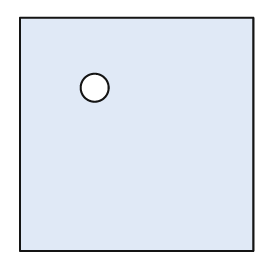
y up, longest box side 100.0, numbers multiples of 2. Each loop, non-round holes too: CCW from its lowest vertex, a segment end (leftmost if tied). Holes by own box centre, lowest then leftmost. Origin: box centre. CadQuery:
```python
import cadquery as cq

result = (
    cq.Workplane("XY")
    .moveTo(-50.0, -50.0)
    .lineTo(50.0, -50.0)
    .lineTo(50.0, 50.0)
    .lineTo(-50.0, 50.0)
    .close()
    .moveTo(-18.0, 20.0)
    .circle(6.0)
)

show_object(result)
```